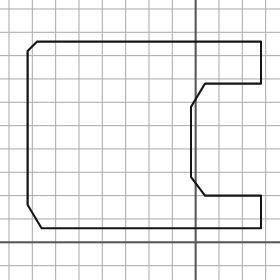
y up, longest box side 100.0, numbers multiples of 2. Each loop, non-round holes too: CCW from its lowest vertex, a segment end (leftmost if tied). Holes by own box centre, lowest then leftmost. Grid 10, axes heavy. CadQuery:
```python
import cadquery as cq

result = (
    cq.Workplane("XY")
    .moveTo(-66.0, 6.0)
    .lineTo(28.0, 6.0)
    .lineTo(28.0, 20.0)
    .lineTo(4.0, 20.0)
    .lineTo(-2.0, 28.0)
    .lineTo(-2.0, 58.0)
    .lineTo(4.0, 68.0)
    .lineTo(28.0, 68.0)
    .lineTo(28.0, 86.0)
    .lineTo(-68.0, 86.0)
    .lineTo(-72.0, 82.0)
    .lineTo(-72.0, 16.0)
    .close()
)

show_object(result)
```